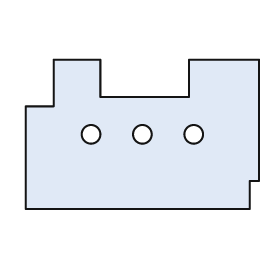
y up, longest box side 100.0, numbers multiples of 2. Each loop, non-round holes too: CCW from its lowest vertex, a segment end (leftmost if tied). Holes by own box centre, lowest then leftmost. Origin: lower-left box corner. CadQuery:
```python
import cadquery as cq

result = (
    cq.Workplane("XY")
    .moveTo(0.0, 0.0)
    .lineTo(96.0, 0.0)
    .lineTo(96.0, 12.0)
    .lineTo(100.0, 12.0)
    .lineTo(100.0, 64.0)
    .lineTo(70.0, 64.0)
    .lineTo(70.0, 48.0)
    .lineTo(32.0, 48.0)
    .lineTo(32.0, 64.0)
    .lineTo(12.0, 64.0)
    .lineTo(12.0, 44.0)
    .lineTo(0.0, 44.0)
    .close()
    .moveTo(28.0, 32.0)
    .circle(4.0)
    .moveTo(50.0, 32.0)
    .circle(4.0)
    .moveTo(72.0, 32.0)
    .circle(4.0)
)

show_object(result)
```